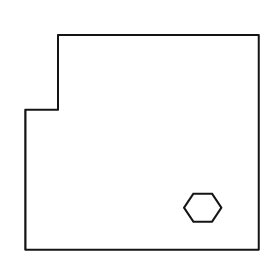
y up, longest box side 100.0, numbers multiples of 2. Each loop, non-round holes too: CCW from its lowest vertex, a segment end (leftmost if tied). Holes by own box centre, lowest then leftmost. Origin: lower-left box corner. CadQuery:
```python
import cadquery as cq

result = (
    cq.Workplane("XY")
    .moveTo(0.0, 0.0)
    .lineTo(100.0, 0.0)
    .lineTo(100.0, 92.0)
    .lineTo(14.0, 92.0)
    .lineTo(14.0, 60.0)
    .lineTo(0.0, 60.0)
    .close()
    .moveTo(72.0, 12.0)
    .lineTo(80.0, 12.0)
    .lineTo(84.0, 18.0)
    .lineTo(80.0, 24.0)
    .lineTo(72.0, 24.0)
    .lineTo(68.0, 18.0)
    .close()
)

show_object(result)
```